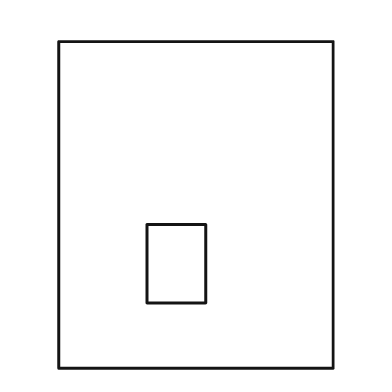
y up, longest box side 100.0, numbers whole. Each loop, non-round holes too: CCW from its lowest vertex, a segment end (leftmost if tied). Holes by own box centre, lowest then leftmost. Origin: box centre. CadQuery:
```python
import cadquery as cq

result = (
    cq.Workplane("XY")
    .moveTo(-42.0, -50.0)
    .lineTo(42.0, -50.0)
    .lineTo(42.0, 50.0)
    .lineTo(-42.0, 50.0)
    .close()
    .moveTo(-15.0, -30.0)
    .lineTo(3.0, -30.0)
    .lineTo(3.0, -6.0)
    .lineTo(-15.0, -6.0)
    .close()
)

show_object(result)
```